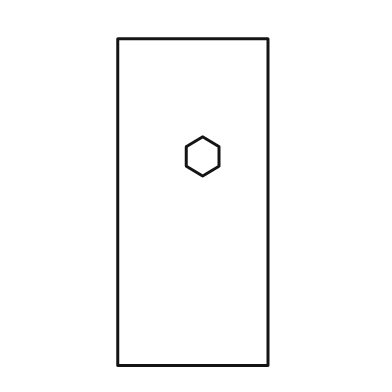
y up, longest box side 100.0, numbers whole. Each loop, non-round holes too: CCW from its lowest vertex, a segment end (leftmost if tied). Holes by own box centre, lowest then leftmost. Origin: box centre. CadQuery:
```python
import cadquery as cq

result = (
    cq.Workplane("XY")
    .moveTo(-23.0, -50.0)
    .lineTo(23.0, -50.0)
    .lineTo(23.0, 50.0)
    .lineTo(-23.0, 50.0)
    .close()
    .moveTo(3.0, 8.0)
    .lineTo(8.0, 11.0)
    .lineTo(8.0, 17.0)
    .lineTo(3.0, 20.0)
    .lineTo(-2.0, 17.0)
    .lineTo(-2.0, 11.0)
    .close()
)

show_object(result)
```